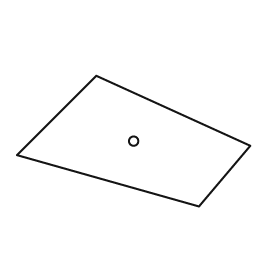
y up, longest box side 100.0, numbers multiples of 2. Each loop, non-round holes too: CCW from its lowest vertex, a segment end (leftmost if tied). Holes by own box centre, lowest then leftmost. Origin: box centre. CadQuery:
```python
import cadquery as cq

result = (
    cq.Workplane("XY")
    .moveTo(28.0, -28.0)
    .lineTo(50.0, -2.0)
    .lineTo(-16.0, 28.0)
    .lineTo(-50.0, -6.0)
    .close()
    .moveTo(0.0, 0.0)
    .circle(2.0)
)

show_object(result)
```